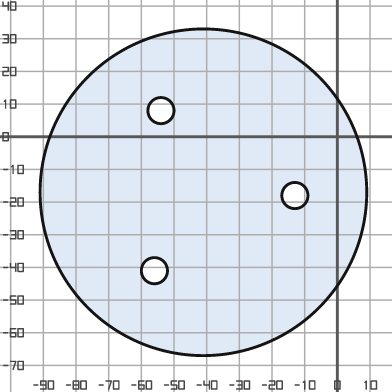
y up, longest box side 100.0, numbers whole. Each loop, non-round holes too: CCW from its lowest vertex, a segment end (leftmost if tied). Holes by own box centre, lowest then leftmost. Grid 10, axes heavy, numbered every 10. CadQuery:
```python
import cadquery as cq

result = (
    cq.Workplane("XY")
    .moveTo(-41.0, -17.0)
    .circle(50.0)
    .moveTo(-56.0, -41.0)
    .circle(4.0)
    .moveTo(-13.0, -18.0)
    .circle(4.0)
    .moveTo(-54.0, 8.0)
    .circle(4.0)
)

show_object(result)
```